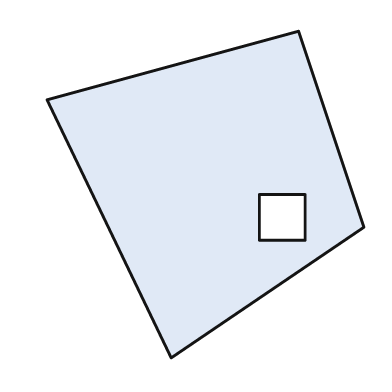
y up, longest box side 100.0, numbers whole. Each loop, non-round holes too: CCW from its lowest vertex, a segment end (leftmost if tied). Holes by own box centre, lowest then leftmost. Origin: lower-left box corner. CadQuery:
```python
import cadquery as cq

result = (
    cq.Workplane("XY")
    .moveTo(38.0, 0.0)
    .lineTo(97.0, 40.0)
    .lineTo(77.0, 100.0)
    .lineTo(0.0, 79.0)
    .close()
    .moveTo(65.0, 36.0)
    .lineTo(79.0, 36.0)
    .lineTo(79.0, 50.0)
    .lineTo(65.0, 50.0)
    .close()
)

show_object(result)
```